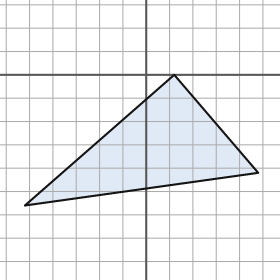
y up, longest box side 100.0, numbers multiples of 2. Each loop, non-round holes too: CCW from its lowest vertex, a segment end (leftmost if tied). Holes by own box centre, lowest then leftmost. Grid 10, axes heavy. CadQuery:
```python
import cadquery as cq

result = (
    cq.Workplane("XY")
    .moveTo(-52.0, -56.0)
    .lineTo(48.0, -42.0)
    .lineTo(12.0, 0.0)
    .close()
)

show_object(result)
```